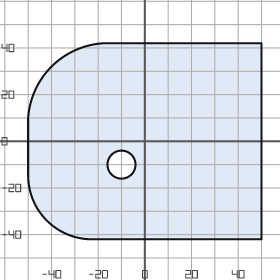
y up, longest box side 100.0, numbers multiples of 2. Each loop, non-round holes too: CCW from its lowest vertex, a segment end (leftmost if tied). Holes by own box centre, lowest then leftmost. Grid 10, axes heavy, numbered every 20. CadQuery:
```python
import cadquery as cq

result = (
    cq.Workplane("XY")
    .moveTo(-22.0, -42.0)
    .lineTo(50.0, -42.0)
    .lineTo(50.0, 42.0)
    .lineTo(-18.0, 42.0)
    .threePointArc((-40.0, 32.0), (-50.0, 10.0))
    .lineTo(-50.0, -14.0)
    .threePointArc((-42.0, -34.0), (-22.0, -42.0))
    .close()
    .moveTo(-10.0, -10.0)
    .circle(6.0)
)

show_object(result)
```